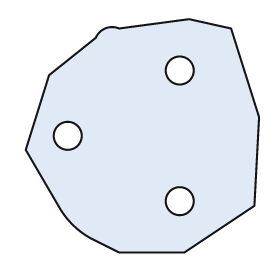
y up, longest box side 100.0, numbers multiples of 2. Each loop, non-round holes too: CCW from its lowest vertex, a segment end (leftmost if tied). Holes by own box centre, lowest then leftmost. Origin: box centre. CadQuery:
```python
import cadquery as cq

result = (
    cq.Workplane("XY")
    .moveTo(-10.0, -50.0)
    .lineTo(18.0, -50.0)
    .lineTo(48.0, -30.0)
    .lineTo(50.0, 8.0)
    .lineTo(38.0, 46.0)
    .lineTo(20.0, 50.0)
    .lineTo(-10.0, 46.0)
    .threePointArc((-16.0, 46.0), (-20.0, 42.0))
    .lineTo(-40.0, 26.0)
    .lineTo(-50.0, -6.0)
    .lineTo(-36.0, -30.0)
    .threePointArc((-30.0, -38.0), (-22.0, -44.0))
    .close()
    .moveTo(16.0, -28.0)
    .circle(6.0)
    .moveTo(-32.0, 0.0)
    .circle(6.0)
    .moveTo(16.0, 28.0)
    .circle(6.0)
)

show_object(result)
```